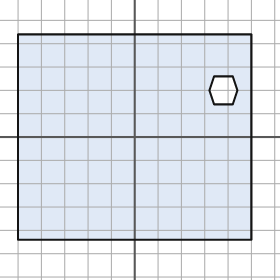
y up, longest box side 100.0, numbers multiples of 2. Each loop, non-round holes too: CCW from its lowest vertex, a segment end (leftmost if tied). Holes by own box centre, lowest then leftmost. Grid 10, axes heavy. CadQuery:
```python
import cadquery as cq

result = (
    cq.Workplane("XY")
    .moveTo(-50.0, -44.0)
    .lineTo(50.0, -44.0)
    .lineTo(50.0, 44.0)
    .lineTo(-50.0, 44.0)
    .close()
    .moveTo(34.0, 14.0)
    .lineTo(42.0, 14.0)
    .lineTo(44.0, 20.0)
    .lineTo(42.0, 26.0)
    .lineTo(34.0, 26.0)
    .lineTo(32.0, 20.0)
    .close()
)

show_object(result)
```